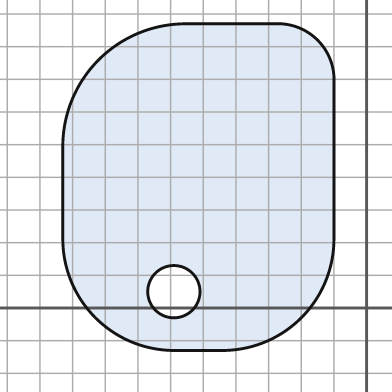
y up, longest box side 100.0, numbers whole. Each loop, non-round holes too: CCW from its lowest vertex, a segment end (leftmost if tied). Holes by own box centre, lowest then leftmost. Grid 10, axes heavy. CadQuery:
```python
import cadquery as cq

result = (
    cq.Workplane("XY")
    .moveTo(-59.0, -13.0)
    .lineTo(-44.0, -13.0)
    .threePointArc((-20.0, -3.0), (-10.0, 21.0))
    .lineTo(-10.0, 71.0)
    .threePointArc((-15.0, 82.0), (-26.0, 87.0))
    .lineTo(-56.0, 87.0)
    .threePointArc((-82.0, 76.0), (-93.0, 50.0))
    .lineTo(-93.0, 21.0)
    .threePointArc((-83.0, -3.0), (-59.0, -13.0))
    .close()
    .moveTo(-59.0, 5.0)
    .circle(8.0)
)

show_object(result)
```